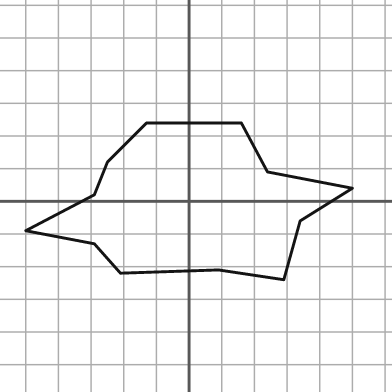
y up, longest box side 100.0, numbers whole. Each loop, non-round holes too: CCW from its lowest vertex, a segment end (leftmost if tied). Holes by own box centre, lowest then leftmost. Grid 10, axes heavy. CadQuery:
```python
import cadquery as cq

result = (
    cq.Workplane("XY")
    .moveTo(29.0, -24.0)
    .lineTo(34.0, -6.0)
    .lineTo(50.0, 4.0)
    .lineTo(24.0, 9.0)
    .lineTo(16.0, 24.0)
    .lineTo(-13.0, 24.0)
    .lineTo(-25.0, 12.0)
    .lineTo(-29.0, 2.0)
    .lineTo(-50.0, -9.0)
    .lineTo(-29.0, -13.0)
    .lineTo(-21.0, -22.0)
    .lineTo(9.0, -21.0)
    .close()
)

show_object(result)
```